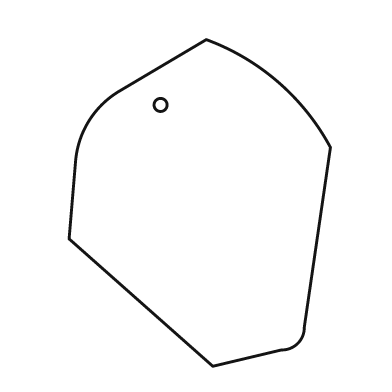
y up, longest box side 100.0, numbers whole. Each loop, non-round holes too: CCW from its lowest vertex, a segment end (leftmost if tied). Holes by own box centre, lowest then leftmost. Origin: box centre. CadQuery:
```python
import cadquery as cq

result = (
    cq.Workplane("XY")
    .moveTo(4.0, -50.0)
    .lineTo(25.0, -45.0)
    .threePointArc((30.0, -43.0), (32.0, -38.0))
    .lineTo(40.0, 17.0)
    .threePointArc((24.0, 37.0), (2.0, 50.0))
    .lineTo(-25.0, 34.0)
    .threePointArc((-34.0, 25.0), (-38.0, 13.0))
    .lineTo(-40.0, -11.0)
    .close()
    .moveTo(-12.0, 30.0)
    .circle(2.0)
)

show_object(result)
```